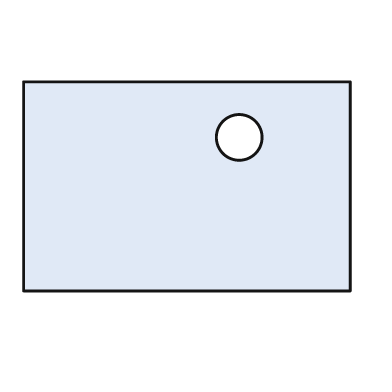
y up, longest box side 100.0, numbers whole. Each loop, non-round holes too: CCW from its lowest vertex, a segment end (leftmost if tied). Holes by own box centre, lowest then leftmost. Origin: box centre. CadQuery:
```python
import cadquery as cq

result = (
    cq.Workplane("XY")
    .moveTo(-50.0, -32.0)
    .lineTo(50.0, -32.0)
    .lineTo(50.0, 32.0)
    .lineTo(-50.0, 32.0)
    .close()
    .moveTo(16.0, 15.0)
    .circle(7.0)
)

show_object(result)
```